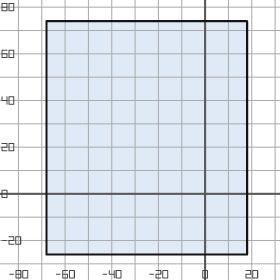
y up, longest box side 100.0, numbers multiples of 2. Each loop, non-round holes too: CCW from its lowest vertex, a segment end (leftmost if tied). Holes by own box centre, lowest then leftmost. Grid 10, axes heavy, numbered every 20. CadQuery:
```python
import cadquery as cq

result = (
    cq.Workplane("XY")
    .moveTo(-68.0, -26.0)
    .lineTo(18.0, -26.0)
    .lineTo(18.0, 74.0)
    .lineTo(-68.0, 74.0)
    .close()
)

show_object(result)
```